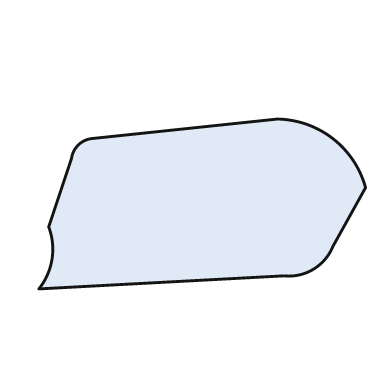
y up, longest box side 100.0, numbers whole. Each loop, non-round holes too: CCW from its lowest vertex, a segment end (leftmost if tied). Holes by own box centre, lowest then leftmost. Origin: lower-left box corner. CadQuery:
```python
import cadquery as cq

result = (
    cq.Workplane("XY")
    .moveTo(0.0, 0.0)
    .lineTo(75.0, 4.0)
    .threePointArc((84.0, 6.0), (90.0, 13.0))
    .lineTo(100.0, 31.0)
    .threePointArc((90.0, 46.0), (73.0, 52.0))
    .lineTo(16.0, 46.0)
    .threePointArc((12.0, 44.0), (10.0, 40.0))
    .lineTo(3.0, 19.0)
    .threePointArc((4.0, 9.0), (0.0, 0.0))
    .close()
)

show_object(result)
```